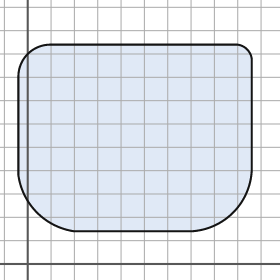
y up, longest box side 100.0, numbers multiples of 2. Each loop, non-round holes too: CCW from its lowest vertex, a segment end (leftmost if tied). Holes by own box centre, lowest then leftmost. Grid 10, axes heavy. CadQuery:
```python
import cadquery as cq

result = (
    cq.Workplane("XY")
    .moveTo(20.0, 14.0)
    .lineTo(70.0, 14.0)
    .threePointArc((88.0, 22.0), (96.0, 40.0))
    .lineTo(96.0, 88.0)
    .threePointArc((94.0, 92.0), (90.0, 94.0))
    .lineTo(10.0, 94.0)
    .threePointArc((0.0, 90.0), (-4.0, 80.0))
    .lineTo(-4.0, 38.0)
    .threePointArc((4.0, 22.0), (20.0, 14.0))
    .close()
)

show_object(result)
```